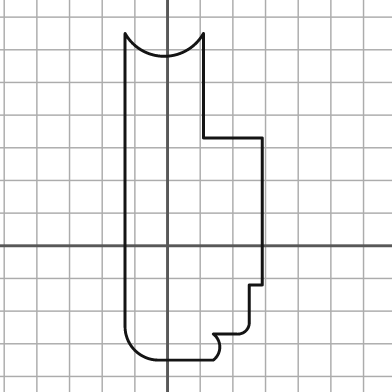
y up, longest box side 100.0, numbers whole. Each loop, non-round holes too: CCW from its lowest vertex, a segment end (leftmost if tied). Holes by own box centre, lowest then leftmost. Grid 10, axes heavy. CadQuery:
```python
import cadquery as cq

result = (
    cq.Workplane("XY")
    .moveTo(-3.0, -35.0)
    .lineTo(14.0, -35.0)
    .threePointArc((16.0, -31.0), (14.0, -27.0))
    .lineTo(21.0, -27.0)
    .threePointArc((24.0, -26.0), (25.0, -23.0))
    .lineTo(25.0, -12.0)
    .lineTo(29.0, -12.0)
    .lineTo(29.0, 33.0)
    .lineTo(11.0, 33.0)
    .lineTo(11.0, 65.0)
    .threePointArc((-1.0, 58.0), (-13.0, 65.0))
    .lineTo(-13.0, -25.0)
    .threePointArc((-10.0, -32.0), (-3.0, -35.0))
    .close()
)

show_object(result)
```